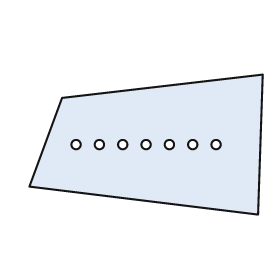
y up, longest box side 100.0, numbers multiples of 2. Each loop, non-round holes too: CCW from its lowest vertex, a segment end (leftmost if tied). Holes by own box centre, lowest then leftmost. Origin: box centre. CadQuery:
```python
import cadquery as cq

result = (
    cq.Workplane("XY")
    .moveTo(48.0, -30.0)
    .lineTo(50.0, 30.0)
    .lineTo(-36.0, 20.0)
    .lineTo(-50.0, -18.0)
    .close()
    .moveTo(-30.0, 0.0)
    .circle(2.0)
    .moveTo(-20.0, 0.0)
    .circle(2.0)
    .moveTo(-10.0, 0.0)
    .circle(2.0)
    .moveTo(0.0, 0.0)
    .circle(2.0)
    .moveTo(10.0, 0.0)
    .circle(2.0)
    .moveTo(20.0, 0.0)
    .circle(2.0)
    .moveTo(30.0, 0.0)
    .circle(2.0)
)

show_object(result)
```